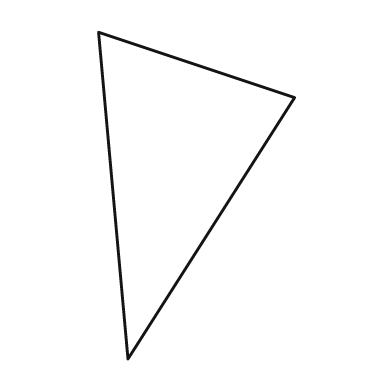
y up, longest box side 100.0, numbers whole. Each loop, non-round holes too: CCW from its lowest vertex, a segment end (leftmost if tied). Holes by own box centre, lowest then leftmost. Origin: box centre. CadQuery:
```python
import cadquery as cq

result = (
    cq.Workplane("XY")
    .moveTo(-21.0, -50.0)
    .lineTo(30.0, 30.0)
    .lineTo(-30.0, 50.0)
    .close()
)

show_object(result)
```